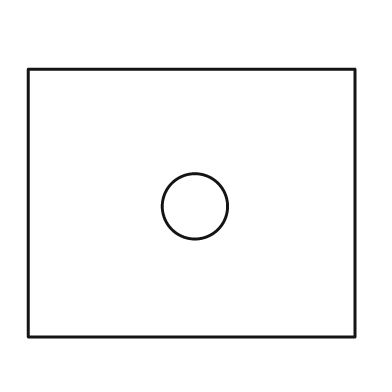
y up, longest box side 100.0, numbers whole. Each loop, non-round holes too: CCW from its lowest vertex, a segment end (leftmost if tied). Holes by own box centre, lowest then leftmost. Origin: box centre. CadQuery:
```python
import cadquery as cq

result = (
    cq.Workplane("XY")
    .moveTo(-50.0, -41.0)
    .lineTo(50.0, -41.0)
    .lineTo(50.0, 41.0)
    .lineTo(-50.0, 41.0)
    .close()
    .moveTo(1.0, -1.0)
    .circle(10.0)
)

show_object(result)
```